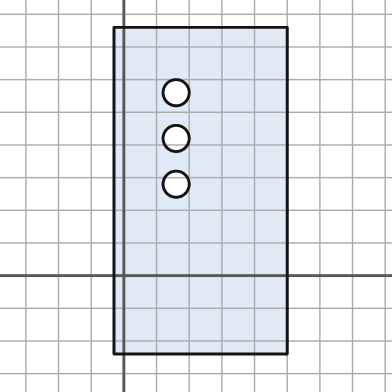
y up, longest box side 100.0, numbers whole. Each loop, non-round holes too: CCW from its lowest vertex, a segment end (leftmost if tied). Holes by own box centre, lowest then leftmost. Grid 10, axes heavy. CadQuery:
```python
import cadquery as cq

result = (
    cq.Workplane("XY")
    .moveTo(-3.0, -24.0)
    .lineTo(50.0, -24.0)
    .lineTo(50.0, 76.0)
    .lineTo(-3.0, 76.0)
    .close()
    .moveTo(16.0, 28.0)
    .circle(4.0)
    .moveTo(16.0, 42.0)
    .circle(4.0)
    .moveTo(16.0, 56.0)
    .circle(4.0)
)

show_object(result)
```